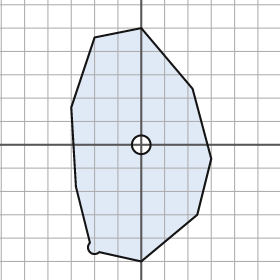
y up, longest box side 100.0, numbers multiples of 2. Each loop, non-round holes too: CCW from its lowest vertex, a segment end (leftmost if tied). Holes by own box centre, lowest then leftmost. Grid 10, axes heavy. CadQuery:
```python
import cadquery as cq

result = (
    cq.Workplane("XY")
    .moveTo(0.0, -50.0)
    .lineTo(24.0, -30.0)
    .lineTo(30.0, -6.0)
    .lineTo(22.0, 24.0)
    .lineTo(0.0, 50.0)
    .lineTo(-20.0, 46.0)
    .lineTo(-30.0, 16.0)
    .lineTo(-28.0, -18.0)
    .lineTo(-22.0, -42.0)
    .threePointArc((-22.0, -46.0), (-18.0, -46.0))
    .close()
    .moveTo(0.0, 0.0)
    .circle(4.0)
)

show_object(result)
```